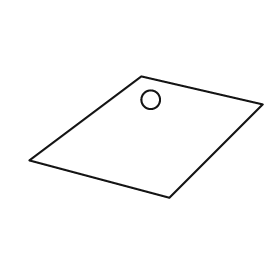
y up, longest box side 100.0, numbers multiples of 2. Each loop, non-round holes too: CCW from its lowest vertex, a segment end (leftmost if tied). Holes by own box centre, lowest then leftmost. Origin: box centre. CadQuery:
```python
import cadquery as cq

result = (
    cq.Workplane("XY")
    .moveTo(10.0, -26.0)
    .lineTo(50.0, 14.0)
    .lineTo(-2.0, 26.0)
    .lineTo(-50.0, -10.0)
    .close()
    .moveTo(2.0, 16.0)
    .circle(4.0)
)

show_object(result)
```